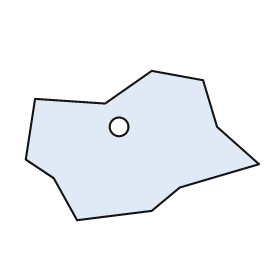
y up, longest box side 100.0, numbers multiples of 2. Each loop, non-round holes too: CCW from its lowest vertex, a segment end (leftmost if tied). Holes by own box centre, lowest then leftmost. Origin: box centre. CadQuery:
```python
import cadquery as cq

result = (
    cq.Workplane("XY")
    .moveTo(-28.0, -32.0)
    .lineTo(4.0, -28.0)
    .lineTo(16.0, -18.0)
    .lineTo(50.0, -8.0)
    .lineTo(32.0, 8.0)
    .lineTo(26.0, 28.0)
    .lineTo(4.0, 32.0)
    .lineTo(-16.0, 18.0)
    .lineTo(-46.0, 20.0)
    .lineTo(-50.0, -6.0)
    .lineTo(-38.0, -14.0)
    .close()
    .moveTo(-10.0, 8.0)
    .circle(4.0)
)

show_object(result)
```